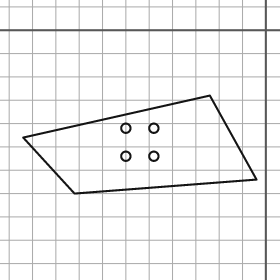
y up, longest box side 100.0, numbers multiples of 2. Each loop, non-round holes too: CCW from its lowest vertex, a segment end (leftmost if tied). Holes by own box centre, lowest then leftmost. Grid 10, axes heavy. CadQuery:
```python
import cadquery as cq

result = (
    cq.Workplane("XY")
    .moveTo(-82.0, -70.0)
    .lineTo(-4.0, -64.0)
    .lineTo(-24.0, -28.0)
    .lineTo(-104.0, -46.0)
    .close()
    .moveTo(-60.0, -54.0)
    .circle(2.0)
    .moveTo(-48.0, -54.0)
    .circle(2.0)
    .moveTo(-60.0, -42.0)
    .circle(2.0)
    .moveTo(-48.0, -42.0)
    .circle(2.0)
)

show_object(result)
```